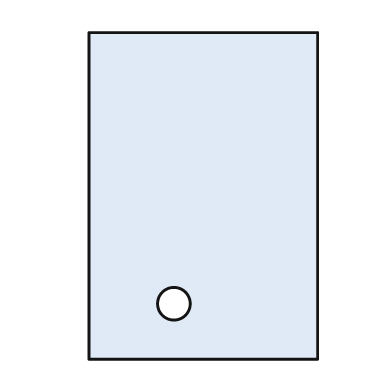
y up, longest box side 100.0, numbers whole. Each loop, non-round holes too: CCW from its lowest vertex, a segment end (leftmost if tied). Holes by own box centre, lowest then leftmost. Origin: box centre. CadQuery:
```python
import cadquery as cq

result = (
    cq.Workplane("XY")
    .moveTo(-35.0, -50.0)
    .lineTo(35.0, -50.0)
    .lineTo(35.0, 50.0)
    .lineTo(-35.0, 50.0)
    .close()
    .moveTo(-9.0, -33.0)
    .circle(5.0)
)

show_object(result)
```